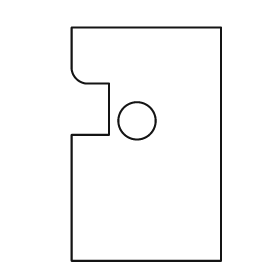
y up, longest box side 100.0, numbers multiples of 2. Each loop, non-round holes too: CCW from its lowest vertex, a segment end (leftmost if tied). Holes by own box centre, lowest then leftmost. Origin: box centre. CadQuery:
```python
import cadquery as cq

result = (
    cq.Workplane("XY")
    .moveTo(-32.0, -50.0)
    .lineTo(32.0, -50.0)
    .lineTo(32.0, 50.0)
    .lineTo(-32.0, 50.0)
    .lineTo(-32.0, 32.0)
    .threePointArc((-30.0, 28.0), (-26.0, 26.0))
    .lineTo(-16.0, 26.0)
    .lineTo(-16.0, 4.0)
    .lineTo(-32.0, 4.0)
    .close()
    .moveTo(-4.0, 10.0)
    .circle(8.0)
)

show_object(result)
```